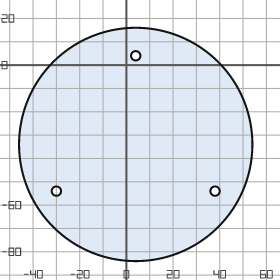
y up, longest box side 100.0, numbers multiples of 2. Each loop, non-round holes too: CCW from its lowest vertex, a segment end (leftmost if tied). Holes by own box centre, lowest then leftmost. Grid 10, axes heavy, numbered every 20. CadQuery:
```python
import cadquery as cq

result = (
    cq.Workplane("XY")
    .moveTo(4.0, -34.0)
    .circle(50.0)
    .moveTo(-30.0, -54.0)
    .circle(2.0)
    .moveTo(38.0, -54.0)
    .circle(2.0)
    .moveTo(4.0, 4.0)
    .circle(2.0)
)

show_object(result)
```